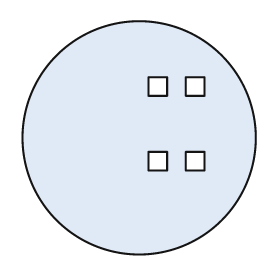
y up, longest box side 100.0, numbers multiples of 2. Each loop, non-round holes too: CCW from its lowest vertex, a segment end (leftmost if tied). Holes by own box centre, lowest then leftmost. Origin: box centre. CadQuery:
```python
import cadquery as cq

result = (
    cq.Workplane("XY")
    .moveTo(0.0, 0.0)
    .circle(50.0)
    .moveTo(4.0, -14.0)
    .lineTo(12.0, -14.0)
    .lineTo(12.0, -6.0)
    .lineTo(4.0, -6.0)
    .close()
    .moveTo(20.0, -14.0)
    .lineTo(28.0, -14.0)
    .lineTo(28.0, -6.0)
    .lineTo(20.0, -6.0)
    .close()
    .moveTo(4.0, 18.0)
    .lineTo(12.0, 18.0)
    .lineTo(12.0, 26.0)
    .lineTo(4.0, 26.0)
    .close()
    .moveTo(20.0, 18.0)
    .lineTo(28.0, 18.0)
    .lineTo(28.0, 26.0)
    .lineTo(20.0, 26.0)
    .close()
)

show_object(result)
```